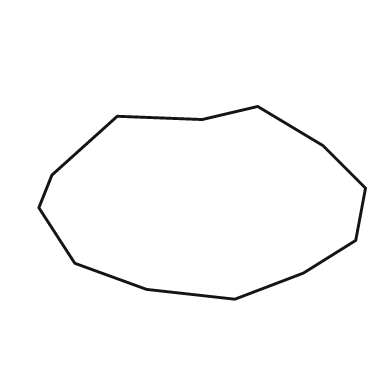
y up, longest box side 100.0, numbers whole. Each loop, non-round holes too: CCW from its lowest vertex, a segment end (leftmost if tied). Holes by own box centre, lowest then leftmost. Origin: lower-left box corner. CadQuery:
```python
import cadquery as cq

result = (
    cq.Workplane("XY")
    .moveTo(60.0, 0.0)
    .lineTo(81.0, 8.0)
    .lineTo(97.0, 18.0)
    .lineTo(100.0, 34.0)
    .lineTo(87.0, 47.0)
    .lineTo(67.0, 59.0)
    .lineTo(50.0, 55.0)
    .lineTo(24.0, 56.0)
    .lineTo(4.0, 38.0)
    .lineTo(0.0, 28.0)
    .lineTo(11.0, 11.0)
    .lineTo(33.0, 3.0)
    .close()
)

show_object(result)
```